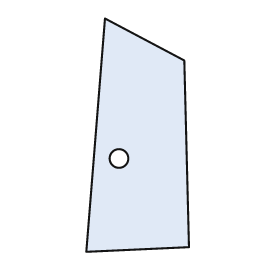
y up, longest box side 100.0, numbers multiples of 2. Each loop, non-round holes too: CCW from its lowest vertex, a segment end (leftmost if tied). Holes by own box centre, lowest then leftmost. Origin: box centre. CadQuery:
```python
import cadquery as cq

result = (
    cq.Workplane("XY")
    .moveTo(-22.0, -50.0)
    .lineTo(22.0, -48.0)
    .lineTo(20.0, 32.0)
    .lineTo(-14.0, 50.0)
    .close()
    .moveTo(-8.0, -10.0)
    .circle(4.0)
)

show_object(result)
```